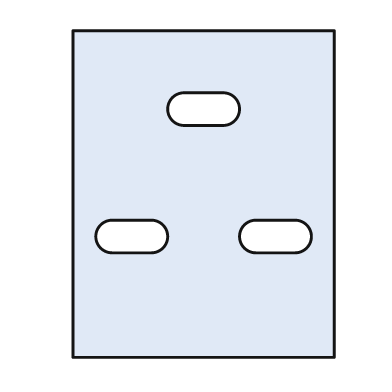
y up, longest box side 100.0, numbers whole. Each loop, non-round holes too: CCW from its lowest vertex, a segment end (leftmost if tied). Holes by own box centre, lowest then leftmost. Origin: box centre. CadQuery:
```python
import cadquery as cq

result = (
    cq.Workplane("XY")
    .moveTo(-40.0, -50.0)
    .lineTo(40.0, -50.0)
    .lineTo(40.0, 50.0)
    .lineTo(-40.0, 50.0)
    .close()
    .moveTo(-28.0, -18.0)
    .lineTo(-16.0, -18.0)
    .threePointArc((-11.0, -13.0), (-16.0, -8.0))
    .lineTo(-28.0, -8.0)
    .threePointArc((-33.0, -13.0), (-28.0, -18.0))
    .close()
    .moveTo(16.0, -18.0)
    .lineTo(28.0, -18.0)
    .threePointArc((33.0, -13.0), (28.0, -8.0))
    .lineTo(16.0, -8.0)
    .threePointArc((11.0, -13.0), (16.0, -18.0))
    .close()
    .moveTo(-6.0, 21.0)
    .lineTo(6.0, 21.0)
    .threePointArc((11.0, 26.0), (6.0, 31.0))
    .lineTo(-6.0, 31.0)
    .threePointArc((-11.0, 26.0), (-6.0, 21.0))
    .close()
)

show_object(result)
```